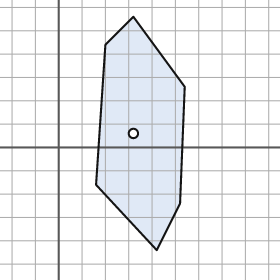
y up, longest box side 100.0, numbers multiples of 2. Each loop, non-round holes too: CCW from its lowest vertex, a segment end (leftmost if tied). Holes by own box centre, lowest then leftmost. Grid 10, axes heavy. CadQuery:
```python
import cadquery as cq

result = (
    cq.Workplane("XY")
    .moveTo(42.0, -44.0)
    .lineTo(52.0, -24.0)
    .lineTo(54.0, 26.0)
    .lineTo(32.0, 56.0)
    .lineTo(20.0, 44.0)
    .lineTo(16.0, -16.0)
    .close()
    .moveTo(32.0, 6.0)
    .circle(2.0)
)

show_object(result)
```